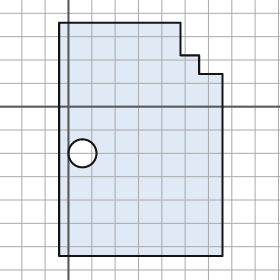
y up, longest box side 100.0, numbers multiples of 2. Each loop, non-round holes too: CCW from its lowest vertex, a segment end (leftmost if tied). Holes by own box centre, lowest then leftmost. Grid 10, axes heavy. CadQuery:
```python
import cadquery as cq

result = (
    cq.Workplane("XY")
    .moveTo(-4.0, -64.0)
    .lineTo(66.0, -64.0)
    .lineTo(66.0, 14.0)
    .lineTo(56.0, 14.0)
    .lineTo(56.0, 22.0)
    .lineTo(48.0, 22.0)
    .lineTo(48.0, 36.0)
    .lineTo(-4.0, 36.0)
    .close()
    .moveTo(6.0, -20.0)
    .circle(6.0)
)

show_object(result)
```